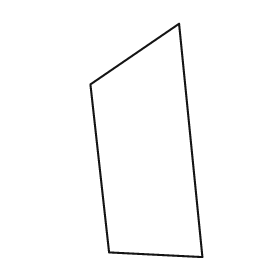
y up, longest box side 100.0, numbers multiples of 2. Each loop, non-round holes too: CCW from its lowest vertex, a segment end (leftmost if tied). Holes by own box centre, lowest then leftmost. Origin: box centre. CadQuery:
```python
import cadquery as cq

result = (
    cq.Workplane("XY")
    .moveTo(24.0, -50.0)
    .lineTo(14.0, 50.0)
    .lineTo(-24.0, 24.0)
    .lineTo(-16.0, -48.0)
    .close()
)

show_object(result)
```